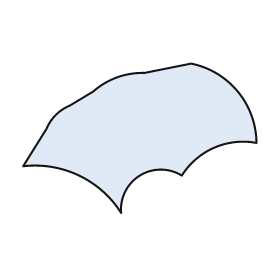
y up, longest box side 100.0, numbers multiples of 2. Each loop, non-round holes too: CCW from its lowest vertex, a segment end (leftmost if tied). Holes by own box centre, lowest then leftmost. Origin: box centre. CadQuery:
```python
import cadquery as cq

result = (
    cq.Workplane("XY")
    .moveTo(-8.0, -32.0)
    .threePointArc((0.0, -16.0), (18.0, -16.0))
    .threePointArc((32.0, -4.0), (50.0, -2.0))
    .threePointArc((42.0, 20.0), (22.0, 32.0))
    .lineTo(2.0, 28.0)
    .threePointArc((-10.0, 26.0), (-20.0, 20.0))
    .lineTo(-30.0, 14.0)
    .threePointArc((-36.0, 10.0), (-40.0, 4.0))
    .lineTo(-50.0, -12.0)
    .threePointArc((-26.0, -16.0), (-8.0, -32.0))
    .close()
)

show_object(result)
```